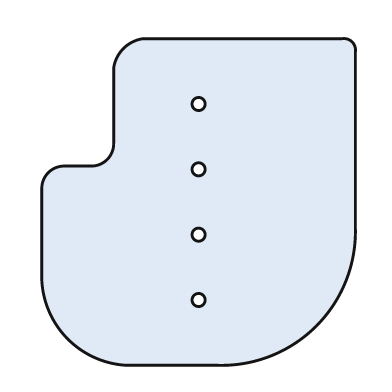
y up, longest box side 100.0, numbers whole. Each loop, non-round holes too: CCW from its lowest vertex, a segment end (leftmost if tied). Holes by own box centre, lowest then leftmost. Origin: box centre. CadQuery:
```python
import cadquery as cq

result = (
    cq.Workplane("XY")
    .moveTo(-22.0, -50.0)
    .lineTo(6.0, -50.0)
    .threePointArc((36.0, -38.0), (48.0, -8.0))
    .lineTo(48.0, 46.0)
    .threePointArc((47.0, 49.0), (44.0, 50.0))
    .lineTo(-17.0, 50.0)
    .threePointArc((-23.0, 47.0), (-26.0, 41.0))
    .lineTo(-26.0, 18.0)
    .threePointArc((-28.0, 13.0), (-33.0, 11.0))
    .lineTo(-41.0, 11.0)
    .threePointArc((-46.0, 9.0), (-48.0, 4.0))
    .lineTo(-48.0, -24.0)
    .threePointArc((-40.0, -42.0), (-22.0, -50.0))
    .close()
    .moveTo(0.0, -30.0)
    .circle(2.0)
    .moveTo(0.0, -10.0)
    .circle(2.0)
    .moveTo(0.0, 10.0)
    .circle(2.0)
    .moveTo(0.0, 30.0)
    .circle(2.0)
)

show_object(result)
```